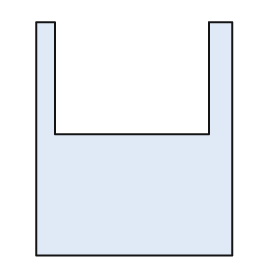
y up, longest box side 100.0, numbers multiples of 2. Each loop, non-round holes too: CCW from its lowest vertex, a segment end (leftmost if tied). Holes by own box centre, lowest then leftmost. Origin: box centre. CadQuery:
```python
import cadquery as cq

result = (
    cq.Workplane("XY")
    .moveTo(-42.0, -50.0)
    .lineTo(42.0, -50.0)
    .lineTo(42.0, 50.0)
    .lineTo(32.0, 50.0)
    .lineTo(32.0, 2.0)
    .lineTo(-34.0, 2.0)
    .lineTo(-34.0, 50.0)
    .lineTo(-42.0, 50.0)
    .close()
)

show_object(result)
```